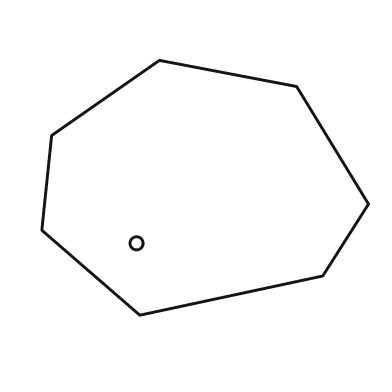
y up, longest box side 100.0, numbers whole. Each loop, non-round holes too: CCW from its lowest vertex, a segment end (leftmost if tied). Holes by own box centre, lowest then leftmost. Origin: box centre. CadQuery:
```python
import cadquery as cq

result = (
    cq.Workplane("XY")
    .moveTo(-20.0, -39.0)
    .lineTo(36.0, -27.0)
    .lineTo(50.0, -5.0)
    .lineTo(28.0, 31.0)
    .lineTo(-14.0, 39.0)
    .lineTo(-47.0, 16.0)
    .lineTo(-50.0, -13.0)
    .close()
    .moveTo(-21.0, -17.0)
    .circle(2.0)
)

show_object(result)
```